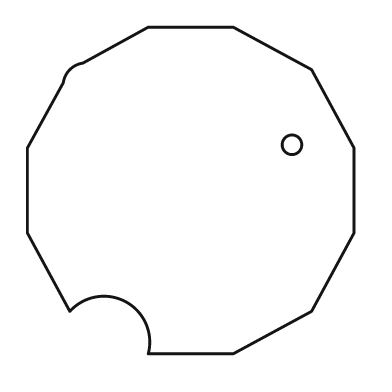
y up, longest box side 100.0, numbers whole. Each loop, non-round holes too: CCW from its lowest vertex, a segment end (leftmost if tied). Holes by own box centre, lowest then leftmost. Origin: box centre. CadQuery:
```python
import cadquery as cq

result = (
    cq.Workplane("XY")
    .moveTo(-13.0, -50.0)
    .lineTo(13.0, -50.0)
    .lineTo(37.0, -37.0)
    .lineTo(50.0, -13.0)
    .lineTo(50.0, 13.0)
    .lineTo(37.0, 37.0)
    .lineTo(13.0, 50.0)
    .lineTo(-13.0, 50.0)
    .lineTo(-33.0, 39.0)
    .threePointArc((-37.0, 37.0), (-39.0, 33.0))
    .lineTo(-50.0, 13.0)
    .lineTo(-50.0, -13.0)
    .lineTo(-37.0, -37.0)
    .threePointArc((-20.0, -34.0), (-13.0, -50.0))
    .close()
    .moveTo(31.0, 14.0)
    .circle(3.0)
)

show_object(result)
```